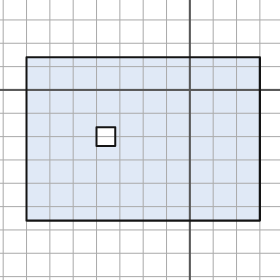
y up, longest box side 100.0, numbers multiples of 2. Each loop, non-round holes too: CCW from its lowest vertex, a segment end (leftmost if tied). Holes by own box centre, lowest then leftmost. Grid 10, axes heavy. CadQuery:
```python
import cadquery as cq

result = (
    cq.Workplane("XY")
    .moveTo(-70.0, -56.0)
    .lineTo(30.0, -56.0)
    .lineTo(30.0, 14.0)
    .lineTo(-70.0, 14.0)
    .close()
    .moveTo(-40.0, -24.0)
    .lineTo(-32.0, -24.0)
    .lineTo(-32.0, -16.0)
    .lineTo(-40.0, -16.0)
    .close()
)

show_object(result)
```